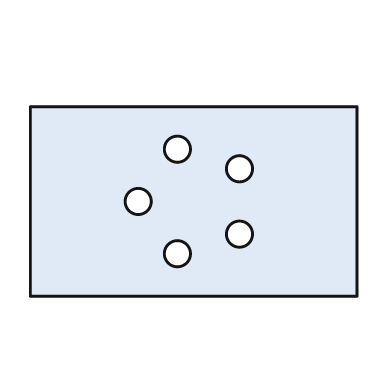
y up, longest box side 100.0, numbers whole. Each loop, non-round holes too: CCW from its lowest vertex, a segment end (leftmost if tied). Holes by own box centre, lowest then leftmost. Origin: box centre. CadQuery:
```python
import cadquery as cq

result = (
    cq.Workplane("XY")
    .moveTo(-50.0, -29.0)
    .lineTo(50.0, -29.0)
    .lineTo(50.0, 29.0)
    .lineTo(-50.0, 29.0)
    .close()
    .moveTo(-5.0, -16.0)
    .circle(4.0)
    .moveTo(14.0, -10.0)
    .circle(4.0)
    .moveTo(-17.0, 0.0)
    .circle(4.0)
    .moveTo(14.0, 10.0)
    .circle(4.0)
    .moveTo(-5.0, 16.0)
    .circle(4.0)
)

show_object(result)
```